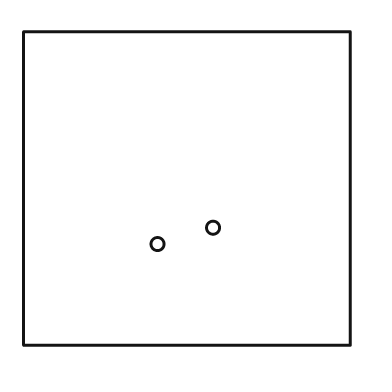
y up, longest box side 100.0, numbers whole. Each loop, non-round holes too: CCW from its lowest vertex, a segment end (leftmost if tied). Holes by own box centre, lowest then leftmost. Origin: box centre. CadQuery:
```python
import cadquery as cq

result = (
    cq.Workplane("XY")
    .moveTo(-50.0, -48.0)
    .lineTo(50.0, -48.0)
    .lineTo(50.0, 48.0)
    .lineTo(-50.0, 48.0)
    .close()
    .moveTo(-9.0, -17.0)
    .circle(2.0)
    .moveTo(8.0, -12.0)
    .circle(2.0)
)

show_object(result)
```